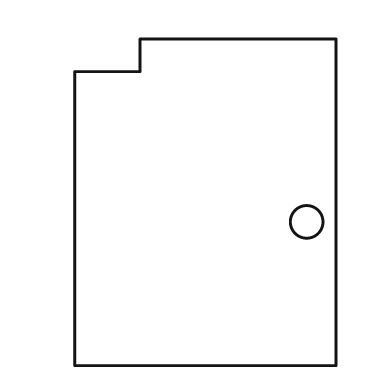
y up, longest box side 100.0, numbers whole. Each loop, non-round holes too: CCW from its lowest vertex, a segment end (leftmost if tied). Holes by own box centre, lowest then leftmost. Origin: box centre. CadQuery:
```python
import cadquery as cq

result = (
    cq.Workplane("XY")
    .moveTo(-40.0, -50.0)
    .lineTo(40.0, -50.0)
    .lineTo(40.0, 50.0)
    .lineTo(-20.0, 50.0)
    .lineTo(-20.0, 40.0)
    .lineTo(-40.0, 40.0)
    .close()
    .moveTo(31.0, -6.0)
    .circle(5.0)
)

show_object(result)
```